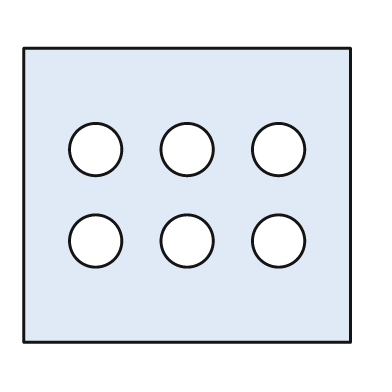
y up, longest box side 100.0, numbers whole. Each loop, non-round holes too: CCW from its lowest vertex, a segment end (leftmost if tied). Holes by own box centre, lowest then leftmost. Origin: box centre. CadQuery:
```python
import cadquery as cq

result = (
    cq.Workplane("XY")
    .moveTo(-50.0, -45.0)
    .lineTo(50.0, -45.0)
    .lineTo(50.0, 45.0)
    .lineTo(-50.0, 45.0)
    .close()
    .moveTo(-28.0, -14.0)
    .circle(8.0)
    .moveTo(0.0, -14.0)
    .circle(8.0)
    .moveTo(28.0, -14.0)
    .circle(8.0)
    .moveTo(-28.0, 14.0)
    .circle(8.0)
    .moveTo(0.0, 14.0)
    .circle(8.0)
    .moveTo(28.0, 14.0)
    .circle(8.0)
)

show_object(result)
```